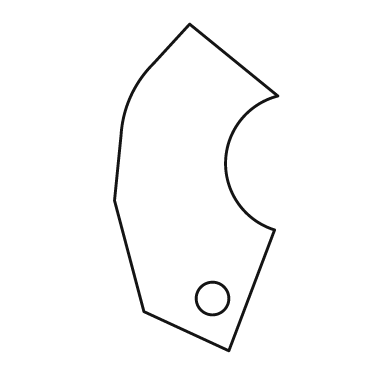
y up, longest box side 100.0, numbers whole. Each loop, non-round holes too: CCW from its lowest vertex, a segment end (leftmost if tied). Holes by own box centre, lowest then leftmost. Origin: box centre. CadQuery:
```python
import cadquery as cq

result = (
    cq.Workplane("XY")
    .moveTo(10.0, -50.0)
    .lineTo(24.0, -13.0)
    .threePointArc((9.0, 8.0), (25.0, 28.0))
    .lineTo(-2.0, 50.0)
    .lineTo(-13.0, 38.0)
    .threePointArc((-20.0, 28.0), (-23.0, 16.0))
    .lineTo(-25.0, -4.0)
    .lineTo(-16.0, -38.0)
    .close()
    .moveTo(5.0, -34.0)
    .circle(5.0)
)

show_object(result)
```